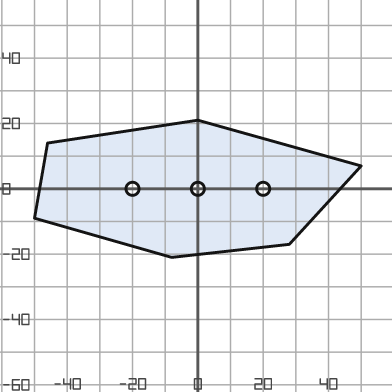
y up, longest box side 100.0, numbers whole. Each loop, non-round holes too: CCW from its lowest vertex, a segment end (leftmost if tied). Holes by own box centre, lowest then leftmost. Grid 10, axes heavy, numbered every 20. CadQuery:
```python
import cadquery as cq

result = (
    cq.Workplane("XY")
    .moveTo(-8.0, -21.0)
    .lineTo(28.0, -17.0)
    .lineTo(50.0, 7.0)
    .lineTo(0.0, 21.0)
    .lineTo(-46.0, 14.0)
    .lineTo(-50.0, -9.0)
    .close()
    .moveTo(-20.0, 0.0)
    .circle(2.0)
    .moveTo(0.0, 0.0)
    .circle(2.0)
    .moveTo(20.0, 0.0)
    .circle(2.0)
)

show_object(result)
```